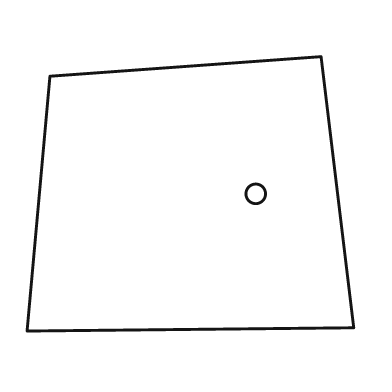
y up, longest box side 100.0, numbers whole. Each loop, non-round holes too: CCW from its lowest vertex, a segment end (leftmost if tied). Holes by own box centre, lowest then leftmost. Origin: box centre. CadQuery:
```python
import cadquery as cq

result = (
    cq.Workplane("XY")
    .moveTo(-50.0, -42.0)
    .lineTo(50.0, -41.0)
    .lineTo(40.0, 42.0)
    .lineTo(-43.0, 36.0)
    .close()
    .moveTo(20.0, 0.0)
    .circle(3.0)
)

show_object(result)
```